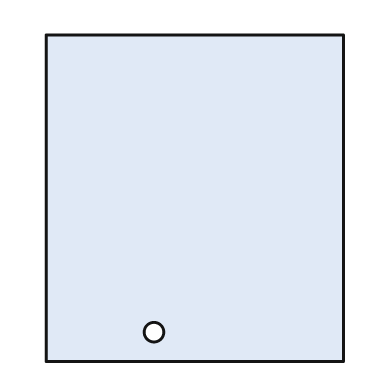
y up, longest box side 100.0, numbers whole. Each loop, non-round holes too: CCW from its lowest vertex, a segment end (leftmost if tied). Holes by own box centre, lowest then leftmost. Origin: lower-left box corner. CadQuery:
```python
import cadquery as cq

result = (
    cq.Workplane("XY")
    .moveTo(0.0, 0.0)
    .lineTo(91.0, 0.0)
    .lineTo(91.0, 100.0)
    .lineTo(0.0, 100.0)
    .close()
    .moveTo(33.0, 9.0)
    .circle(3.0)
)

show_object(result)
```